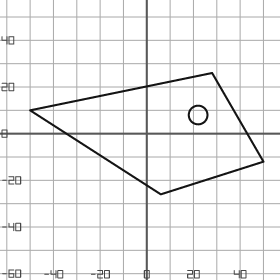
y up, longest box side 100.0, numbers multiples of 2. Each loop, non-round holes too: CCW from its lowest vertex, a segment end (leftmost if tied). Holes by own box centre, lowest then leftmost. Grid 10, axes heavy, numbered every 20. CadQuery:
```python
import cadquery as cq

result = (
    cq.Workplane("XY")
    .moveTo(6.0, -26.0)
    .lineTo(50.0, -12.0)
    .lineTo(28.0, 26.0)
    .lineTo(-50.0, 10.0)
    .close()
    .moveTo(22.0, 8.0)
    .circle(4.0)
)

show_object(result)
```